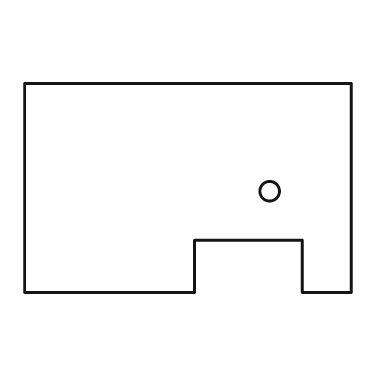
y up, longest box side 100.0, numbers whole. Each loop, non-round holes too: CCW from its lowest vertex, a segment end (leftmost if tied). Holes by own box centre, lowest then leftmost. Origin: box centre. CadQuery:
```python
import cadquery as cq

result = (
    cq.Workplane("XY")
    .moveTo(-50.0, -32.0)
    .lineTo(2.0, -32.0)
    .lineTo(2.0, -16.0)
    .lineTo(35.0, -16.0)
    .lineTo(35.0, -32.0)
    .lineTo(50.0, -32.0)
    .lineTo(50.0, 32.0)
    .lineTo(-50.0, 32.0)
    .close()
    .moveTo(25.0, -1.0)
    .circle(3.0)
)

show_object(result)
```